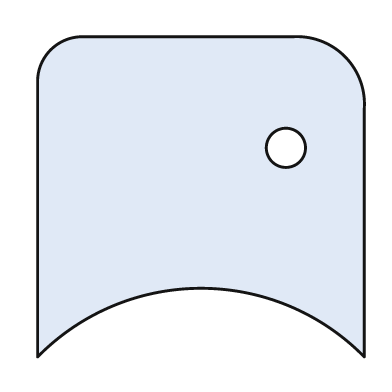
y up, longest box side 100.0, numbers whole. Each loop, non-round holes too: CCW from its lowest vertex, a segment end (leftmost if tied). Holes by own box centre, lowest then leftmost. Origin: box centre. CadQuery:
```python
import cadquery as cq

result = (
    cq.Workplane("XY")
    .moveTo(-50.0, -49.0)
    .threePointArc((0.0, -28.0), (50.0, -49.0))
    .lineTo(50.0, 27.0)
    .threePointArc((44.0, 43.0), (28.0, 49.0))
    .lineTo(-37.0, 49.0)
    .threePointArc((-46.0, 45.0), (-50.0, 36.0))
    .close()
    .moveTo(26.0, 15.0)
    .circle(6.0)
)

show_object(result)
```